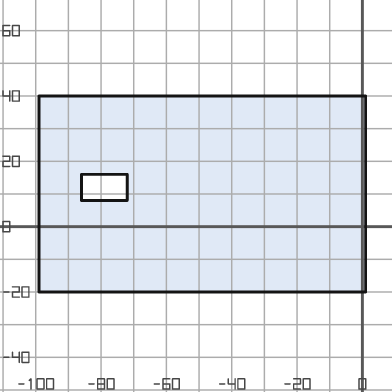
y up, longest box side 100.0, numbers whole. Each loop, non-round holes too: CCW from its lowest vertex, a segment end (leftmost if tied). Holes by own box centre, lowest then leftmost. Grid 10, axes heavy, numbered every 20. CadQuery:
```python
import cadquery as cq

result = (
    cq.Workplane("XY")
    .moveTo(-99.0, -20.0)
    .lineTo(1.0, -20.0)
    .lineTo(1.0, 40.0)
    .lineTo(-99.0, 40.0)
    .close()
    .moveTo(-86.0, 8.0)
    .lineTo(-72.0, 8.0)
    .lineTo(-72.0, 16.0)
    .lineTo(-86.0, 16.0)
    .close()
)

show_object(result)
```